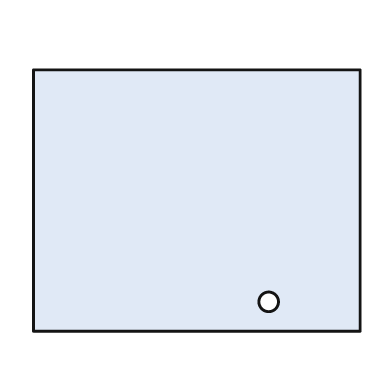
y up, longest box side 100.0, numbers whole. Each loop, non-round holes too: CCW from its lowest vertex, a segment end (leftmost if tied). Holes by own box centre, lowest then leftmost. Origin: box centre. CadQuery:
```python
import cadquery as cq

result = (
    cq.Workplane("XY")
    .moveTo(-50.0, -40.0)
    .lineTo(50.0, -40.0)
    .lineTo(50.0, 40.0)
    .lineTo(-50.0, 40.0)
    .close()
    .moveTo(22.0, -31.0)
    .circle(3.0)
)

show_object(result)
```